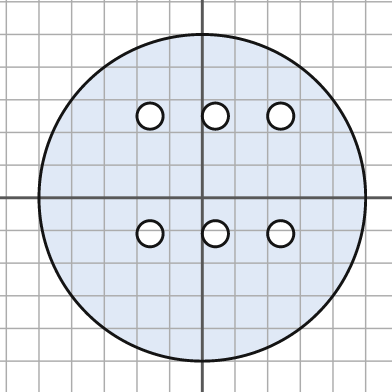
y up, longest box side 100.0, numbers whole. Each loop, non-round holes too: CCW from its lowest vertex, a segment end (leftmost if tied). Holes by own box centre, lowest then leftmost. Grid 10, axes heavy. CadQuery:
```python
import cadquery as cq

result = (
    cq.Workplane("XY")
    .moveTo(0.0, 0.0)
    .circle(50.0)
    .moveTo(-16.0, -11.0)
    .circle(4.0)
    .moveTo(4.0, -11.0)
    .circle(4.0)
    .moveTo(24.0, -11.0)
    .circle(4.0)
    .moveTo(-16.0, 25.0)
    .circle(4.0)
    .moveTo(4.0, 25.0)
    .circle(4.0)
    .moveTo(24.0, 25.0)
    .circle(4.0)
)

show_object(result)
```